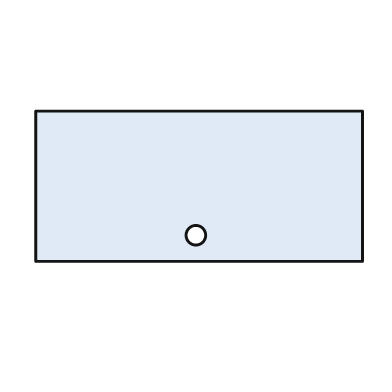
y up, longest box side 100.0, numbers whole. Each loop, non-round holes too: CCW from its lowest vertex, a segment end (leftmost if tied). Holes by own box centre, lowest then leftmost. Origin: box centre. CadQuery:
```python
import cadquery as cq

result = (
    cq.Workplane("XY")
    .moveTo(-50.0, -23.0)
    .lineTo(50.0, -23.0)
    .lineTo(50.0, 23.0)
    .lineTo(-50.0, 23.0)
    .close()
    .moveTo(-1.0, -15.0)
    .circle(3.0)
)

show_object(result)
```